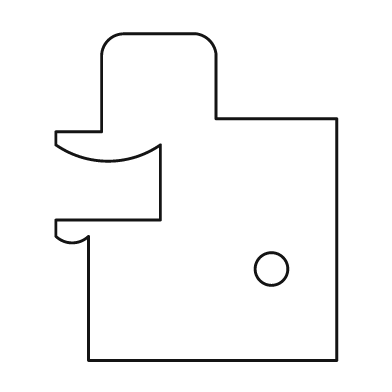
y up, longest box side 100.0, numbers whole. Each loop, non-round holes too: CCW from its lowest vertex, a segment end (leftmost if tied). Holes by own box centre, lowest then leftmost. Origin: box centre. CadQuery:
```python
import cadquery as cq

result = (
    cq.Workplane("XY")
    .moveTo(-33.0, -50.0)
    .lineTo(43.0, -50.0)
    .lineTo(43.0, 24.0)
    .lineTo(6.0, 24.0)
    .lineTo(6.0, 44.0)
    .threePointArc((4.0, 48.0), (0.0, 50.0))
    .lineTo(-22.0, 50.0)
    .threePointArc((-27.0, 48.0), (-29.0, 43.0))
    .lineTo(-29.0, 20.0)
    .lineTo(-43.0, 20.0)
    .lineTo(-43.0, 16.0)
    .threePointArc((-27.0, 11.0), (-11.0, 16.0))
    .lineTo(-11.0, -7.0)
    .lineTo(-43.0, -7.0)
    .lineTo(-43.0, -12.0)
    .threePointArc((-38.0, -14.0), (-33.0, -12.0))
    .close()
    .moveTo(23.0, -22.0)
    .circle(5.0)
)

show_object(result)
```